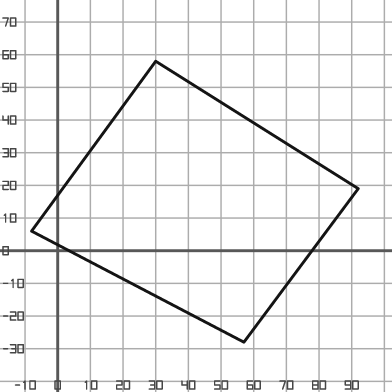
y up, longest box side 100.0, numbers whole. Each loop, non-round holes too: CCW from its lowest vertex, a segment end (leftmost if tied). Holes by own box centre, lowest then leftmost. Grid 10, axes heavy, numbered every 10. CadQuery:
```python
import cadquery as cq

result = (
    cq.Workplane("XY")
    .moveTo(57.0, -28.0)
    .lineTo(92.0, 19.0)
    .lineTo(30.0, 58.0)
    .lineTo(-8.0, 6.0)
    .close()
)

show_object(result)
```